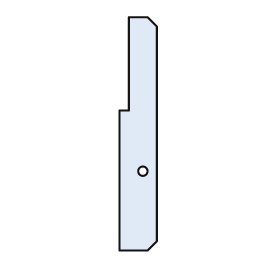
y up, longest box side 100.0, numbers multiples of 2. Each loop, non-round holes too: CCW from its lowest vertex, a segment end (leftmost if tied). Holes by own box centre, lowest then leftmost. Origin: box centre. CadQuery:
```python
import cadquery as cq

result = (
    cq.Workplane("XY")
    .moveTo(-8.0, -50.0)
    .lineTo(4.0, -50.0)
    .lineTo(8.0, -46.0)
    .lineTo(8.0, 46.0)
    .lineTo(4.0, 50.0)
    .lineTo(-4.0, 50.0)
    .lineTo(-4.0, 10.0)
    .lineTo(-8.0, 10.0)
    .close()
    .moveTo(2.0, -16.0)
    .circle(2.0)
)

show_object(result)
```